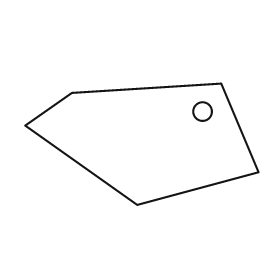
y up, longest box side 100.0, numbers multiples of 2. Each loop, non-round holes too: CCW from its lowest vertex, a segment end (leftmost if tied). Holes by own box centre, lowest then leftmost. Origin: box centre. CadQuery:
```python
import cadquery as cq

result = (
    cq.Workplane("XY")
    .moveTo(-2.0, -26.0)
    .lineTo(50.0, -12.0)
    .lineTo(34.0, 26.0)
    .lineTo(-30.0, 22.0)
    .lineTo(-50.0, 8.0)
    .close()
    .moveTo(26.0, 14.0)
    .circle(4.0)
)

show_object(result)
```